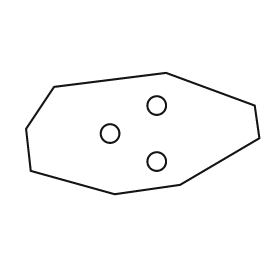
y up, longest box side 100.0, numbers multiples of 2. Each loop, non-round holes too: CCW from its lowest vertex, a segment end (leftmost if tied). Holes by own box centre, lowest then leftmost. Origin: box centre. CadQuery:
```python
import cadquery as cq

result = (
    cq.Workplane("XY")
    .moveTo(-12.0, -26.0)
    .lineTo(16.0, -22.0)
    .lineTo(50.0, -2.0)
    .lineTo(48.0, 12.0)
    .lineTo(10.0, 26.0)
    .lineTo(-38.0, 20.0)
    .lineTo(-50.0, 2.0)
    .lineTo(-48.0, -16.0)
    .close()
    .moveTo(6.0, -12.0)
    .circle(4.0)
    .moveTo(-14.0, 0.0)
    .circle(4.0)
    .moveTo(6.0, 12.0)
    .circle(4.0)
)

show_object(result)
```